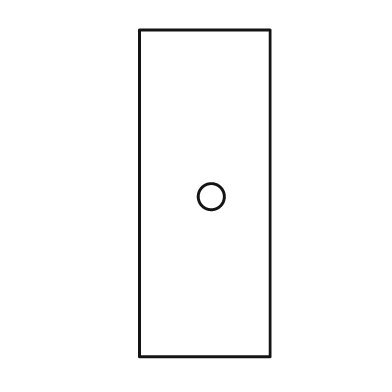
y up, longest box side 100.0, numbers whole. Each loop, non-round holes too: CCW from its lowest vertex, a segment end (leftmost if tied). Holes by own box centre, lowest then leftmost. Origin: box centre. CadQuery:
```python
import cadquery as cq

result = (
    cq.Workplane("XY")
    .moveTo(-20.0, -50.0)
    .lineTo(20.0, -50.0)
    .lineTo(20.0, 50.0)
    .lineTo(-20.0, 50.0)
    .close()
    .moveTo(2.0, -1.0)
    .circle(4.0)
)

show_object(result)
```